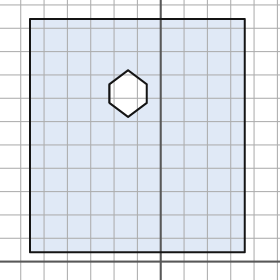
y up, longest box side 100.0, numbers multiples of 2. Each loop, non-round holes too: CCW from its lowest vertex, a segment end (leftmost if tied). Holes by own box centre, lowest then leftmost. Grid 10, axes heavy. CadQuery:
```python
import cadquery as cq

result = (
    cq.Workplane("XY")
    .moveTo(-56.0, 4.0)
    .lineTo(36.0, 4.0)
    .lineTo(36.0, 104.0)
    .lineTo(-56.0, 104.0)
    .close()
    .moveTo(-14.0, 62.0)
    .lineTo(-6.0, 68.0)
    .lineTo(-6.0, 76.0)
    .lineTo(-14.0, 82.0)
    .lineTo(-22.0, 76.0)
    .lineTo(-22.0, 68.0)
    .close()
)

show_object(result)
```